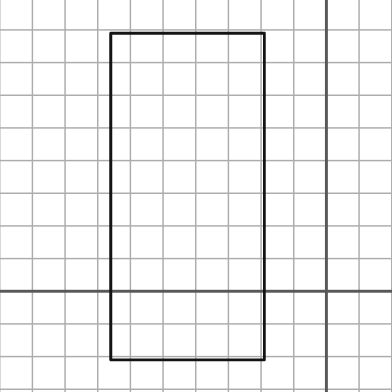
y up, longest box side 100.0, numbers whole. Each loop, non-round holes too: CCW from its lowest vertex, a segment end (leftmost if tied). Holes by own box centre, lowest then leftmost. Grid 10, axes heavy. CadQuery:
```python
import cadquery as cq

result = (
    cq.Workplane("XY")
    .moveTo(-66.0, -21.0)
    .lineTo(-19.0, -21.0)
    .lineTo(-19.0, 79.0)
    .lineTo(-66.0, 79.0)
    .close()
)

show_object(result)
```